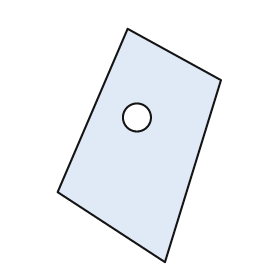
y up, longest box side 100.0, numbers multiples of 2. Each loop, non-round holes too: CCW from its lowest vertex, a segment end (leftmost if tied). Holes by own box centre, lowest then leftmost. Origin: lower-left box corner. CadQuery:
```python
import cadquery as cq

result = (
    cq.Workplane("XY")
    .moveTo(46.0, 0.0)
    .lineTo(70.0, 78.0)
    .lineTo(30.0, 100.0)
    .lineTo(0.0, 30.0)
    .close()
    .moveTo(34.0, 62.0)
    .circle(6.0)
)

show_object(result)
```